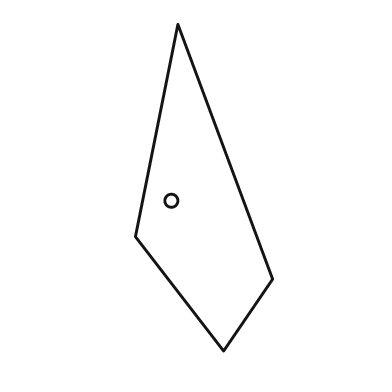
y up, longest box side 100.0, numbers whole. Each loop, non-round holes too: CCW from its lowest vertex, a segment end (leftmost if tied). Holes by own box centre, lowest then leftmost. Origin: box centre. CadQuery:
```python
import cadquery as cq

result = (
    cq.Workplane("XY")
    .moveTo(6.0, -50.0)
    .lineTo(21.0, -28.0)
    .lineTo(-8.0, 50.0)
    .lineTo(-21.0, -15.0)
    .close()
    .moveTo(-10.0, -4.0)
    .circle(2.0)
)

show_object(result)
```